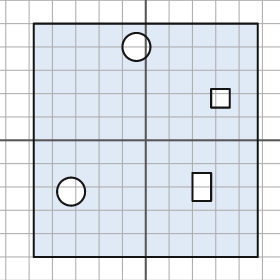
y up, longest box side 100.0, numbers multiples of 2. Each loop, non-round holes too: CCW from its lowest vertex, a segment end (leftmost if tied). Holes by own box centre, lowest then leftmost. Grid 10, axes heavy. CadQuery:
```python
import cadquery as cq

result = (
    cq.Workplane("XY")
    .moveTo(-48.0, -50.0)
    .lineTo(48.0, -50.0)
    .lineTo(48.0, 50.0)
    .lineTo(-48.0, 50.0)
    .close()
    .moveTo(-32.0, -22.0)
    .circle(6.0)
    .moveTo(20.0, -26.0)
    .lineTo(28.0, -26.0)
    .lineTo(28.0, -14.0)
    .lineTo(20.0, -14.0)
    .close()
    .moveTo(28.0, 14.0)
    .lineTo(36.0, 14.0)
    .lineTo(36.0, 22.0)
    .lineTo(28.0, 22.0)
    .close()
    .moveTo(-4.0, 40.0)
    .circle(6.0)
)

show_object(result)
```